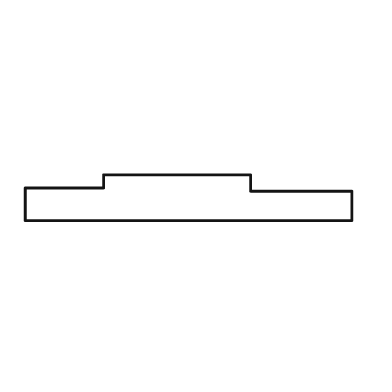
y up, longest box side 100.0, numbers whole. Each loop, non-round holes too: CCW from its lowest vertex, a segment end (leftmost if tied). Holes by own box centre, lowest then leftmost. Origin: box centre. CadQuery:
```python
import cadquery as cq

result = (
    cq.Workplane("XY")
    .moveTo(-50.0, -7.0)
    .lineTo(50.0, -7.0)
    .lineTo(50.0, 2.0)
    .lineTo(19.0, 2.0)
    .lineTo(19.0, 7.0)
    .lineTo(-26.0, 7.0)
    .lineTo(-26.0, 3.0)
    .lineTo(-50.0, 3.0)
    .close()
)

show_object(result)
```